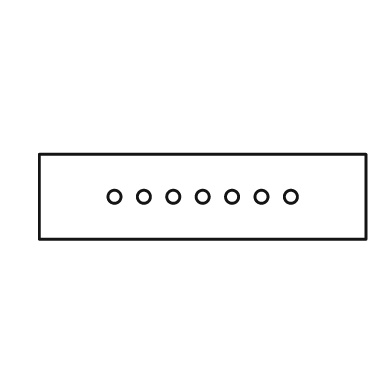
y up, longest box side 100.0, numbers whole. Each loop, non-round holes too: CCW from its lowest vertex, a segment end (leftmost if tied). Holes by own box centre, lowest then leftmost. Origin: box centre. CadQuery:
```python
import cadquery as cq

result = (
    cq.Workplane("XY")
    .moveTo(-50.0, -13.0)
    .lineTo(50.0, -13.0)
    .lineTo(50.0, 13.0)
    .lineTo(-50.0, 13.0)
    .close()
    .moveTo(-27.0, 0.0)
    .circle(2.0)
    .moveTo(-18.0, 0.0)
    .circle(2.0)
    .moveTo(-9.0, 0.0)
    .circle(2.0)
    .moveTo(0.0, 0.0)
    .circle(2.0)
    .moveTo(9.0, 0.0)
    .circle(2.0)
    .moveTo(18.0, 0.0)
    .circle(2.0)
    .moveTo(27.0, 0.0)
    .circle(2.0)
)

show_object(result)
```